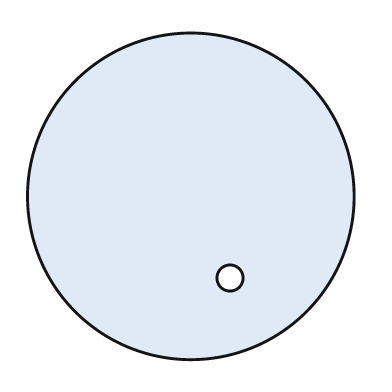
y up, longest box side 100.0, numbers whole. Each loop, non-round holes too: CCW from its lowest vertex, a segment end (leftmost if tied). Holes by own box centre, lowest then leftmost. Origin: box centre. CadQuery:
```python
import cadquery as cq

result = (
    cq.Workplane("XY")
    .moveTo(0.0, 0.0)
    .circle(50.0)
    .moveTo(12.0, -25.0)
    .circle(4.0)
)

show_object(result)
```